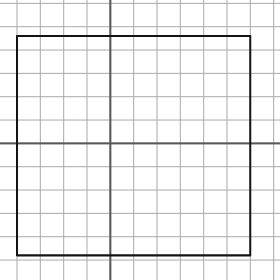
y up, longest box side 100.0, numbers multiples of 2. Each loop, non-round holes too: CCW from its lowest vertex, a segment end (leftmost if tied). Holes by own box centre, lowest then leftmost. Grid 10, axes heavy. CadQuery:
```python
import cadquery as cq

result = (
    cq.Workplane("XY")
    .moveTo(-40.0, -48.0)
    .lineTo(60.0, -48.0)
    .lineTo(60.0, 46.0)
    .lineTo(-40.0, 46.0)
    .close()
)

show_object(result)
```